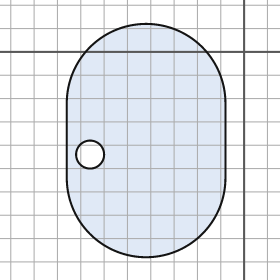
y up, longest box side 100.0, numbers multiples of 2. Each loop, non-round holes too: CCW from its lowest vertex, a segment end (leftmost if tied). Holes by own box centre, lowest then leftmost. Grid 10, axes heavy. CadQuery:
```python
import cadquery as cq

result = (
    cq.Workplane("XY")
    .moveTo(-76.0, -54.0)
    .threePointArc((-42.0, -88.0), (-8.0, -54.0))
    .lineTo(-8.0, -22.0)
    .threePointArc((-42.0, 12.0), (-76.0, -22.0))
    .close()
    .moveTo(-66.0, -44.0)
    .circle(6.0)
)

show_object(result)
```